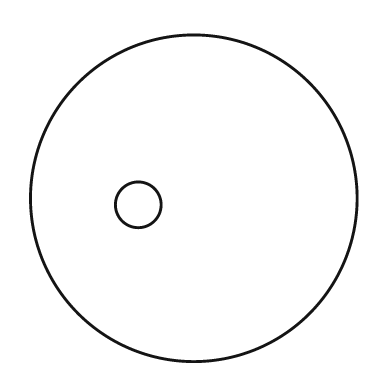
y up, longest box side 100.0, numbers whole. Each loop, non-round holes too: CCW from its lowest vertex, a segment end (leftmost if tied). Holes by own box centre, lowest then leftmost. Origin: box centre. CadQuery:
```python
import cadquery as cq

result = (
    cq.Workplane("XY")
    .moveTo(0.0, 0.0)
    .circle(50.0)
    .moveTo(-17.0, -2.0)
    .circle(7.0)
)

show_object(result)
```